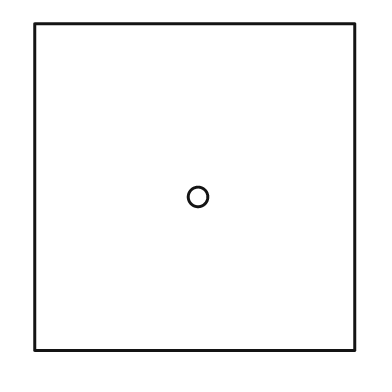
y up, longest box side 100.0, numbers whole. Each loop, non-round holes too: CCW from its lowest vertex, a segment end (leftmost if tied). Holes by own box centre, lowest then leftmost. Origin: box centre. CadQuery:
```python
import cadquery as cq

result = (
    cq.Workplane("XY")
    .moveTo(-49.0, -50.0)
    .lineTo(49.0, -50.0)
    .lineTo(49.0, 50.0)
    .lineTo(-49.0, 50.0)
    .close()
    .moveTo(1.0, -3.0)
    .circle(3.0)
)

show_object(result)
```